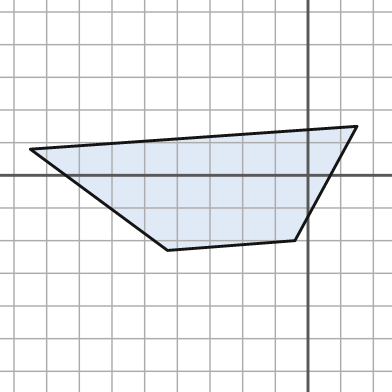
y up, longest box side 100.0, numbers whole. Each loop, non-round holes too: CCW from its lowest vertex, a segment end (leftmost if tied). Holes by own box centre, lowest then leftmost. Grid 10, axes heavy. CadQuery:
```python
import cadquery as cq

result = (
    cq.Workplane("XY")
    .moveTo(-43.0, -23.0)
    .lineTo(-4.0, -20.0)
    .lineTo(15.0, 15.0)
    .lineTo(-85.0, 8.0)
    .close()
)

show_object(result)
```